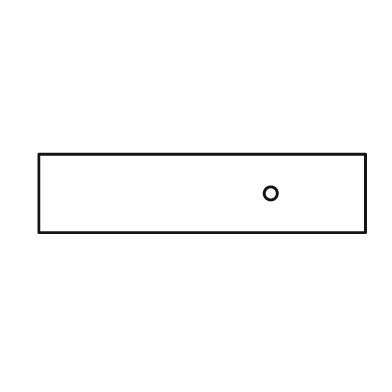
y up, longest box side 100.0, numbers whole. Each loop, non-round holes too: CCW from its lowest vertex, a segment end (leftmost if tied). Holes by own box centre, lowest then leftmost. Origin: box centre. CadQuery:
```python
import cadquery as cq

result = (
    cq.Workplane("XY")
    .moveTo(-50.0, -12.0)
    .lineTo(50.0, -12.0)
    .lineTo(50.0, 12.0)
    .lineTo(-50.0, 12.0)
    .close()
    .moveTo(21.0, 0.0)
    .circle(2.0)
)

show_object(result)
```